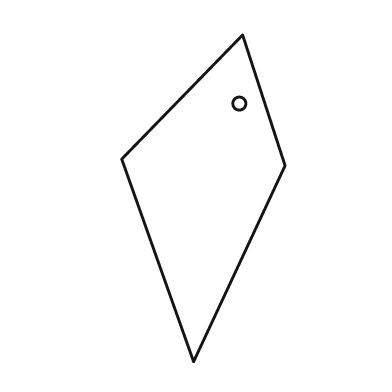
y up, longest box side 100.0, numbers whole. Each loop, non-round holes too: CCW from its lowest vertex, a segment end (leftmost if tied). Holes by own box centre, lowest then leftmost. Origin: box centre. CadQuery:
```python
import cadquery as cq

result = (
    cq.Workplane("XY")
    .moveTo(-3.0, -50.0)
    .lineTo(25.0, 10.0)
    .lineTo(12.0, 50.0)
    .lineTo(-25.0, 12.0)
    .close()
    .moveTo(11.0, 29.0)
    .circle(2.0)
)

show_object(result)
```